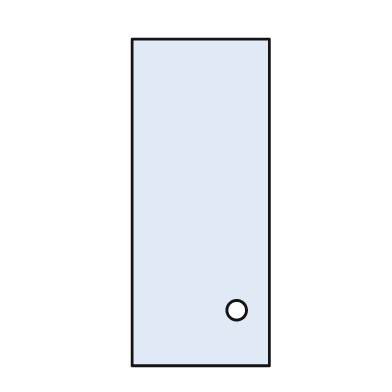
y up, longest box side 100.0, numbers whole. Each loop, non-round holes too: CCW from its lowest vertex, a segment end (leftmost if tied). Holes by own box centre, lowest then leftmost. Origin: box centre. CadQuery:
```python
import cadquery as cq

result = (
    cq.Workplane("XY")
    .moveTo(-21.0, -50.0)
    .lineTo(21.0, -50.0)
    .lineTo(21.0, 50.0)
    .lineTo(-21.0, 50.0)
    .close()
    .moveTo(11.0, -33.0)
    .circle(3.0)
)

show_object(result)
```